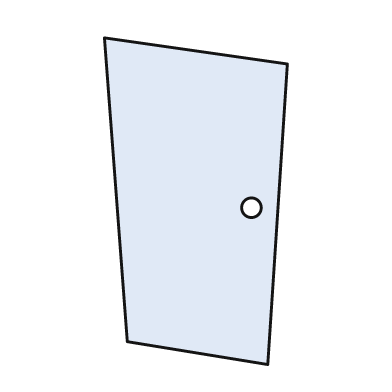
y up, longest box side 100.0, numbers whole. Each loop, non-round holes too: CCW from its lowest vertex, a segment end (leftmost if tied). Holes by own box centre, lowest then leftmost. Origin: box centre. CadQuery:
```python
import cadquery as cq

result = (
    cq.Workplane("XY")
    .moveTo(22.0, -50.0)
    .lineTo(28.0, 42.0)
    .lineTo(-28.0, 50.0)
    .lineTo(-21.0, -43.0)
    .close()
    .moveTo(17.0, -2.0)
    .circle(3.0)
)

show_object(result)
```